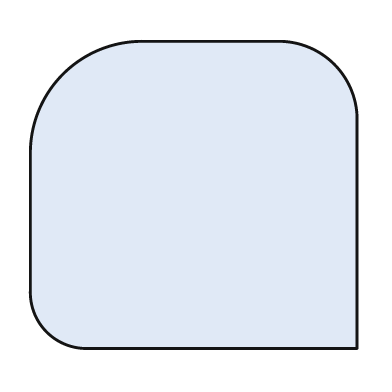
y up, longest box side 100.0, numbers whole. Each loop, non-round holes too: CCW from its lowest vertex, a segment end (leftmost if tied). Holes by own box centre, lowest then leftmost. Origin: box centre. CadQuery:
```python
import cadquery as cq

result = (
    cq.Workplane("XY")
    .moveTo(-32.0, -47.0)
    .lineTo(50.0, -47.0)
    .lineTo(50.0, 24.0)
    .threePointArc((43.0, 40.0), (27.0, 47.0))
    .lineTo(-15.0, 47.0)
    .threePointArc((-40.0, 37.0), (-50.0, 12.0))
    .lineTo(-50.0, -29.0)
    .threePointArc((-45.0, -42.0), (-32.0, -47.0))
    .close()
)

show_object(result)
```